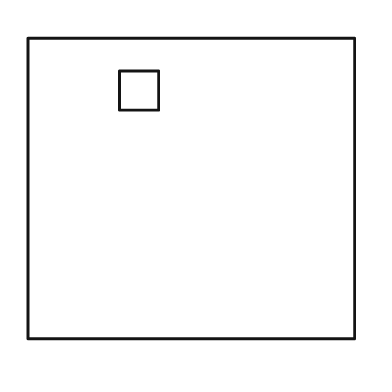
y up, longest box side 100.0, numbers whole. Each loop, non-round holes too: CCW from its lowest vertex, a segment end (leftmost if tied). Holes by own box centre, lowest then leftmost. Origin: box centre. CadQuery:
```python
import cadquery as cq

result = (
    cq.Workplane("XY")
    .moveTo(-50.0, -46.0)
    .lineTo(50.0, -46.0)
    .lineTo(50.0, 46.0)
    .lineTo(-50.0, 46.0)
    .close()
    .moveTo(-22.0, 24.0)
    .lineTo(-10.0, 24.0)
    .lineTo(-10.0, 36.0)
    .lineTo(-22.0, 36.0)
    .close()
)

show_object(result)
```